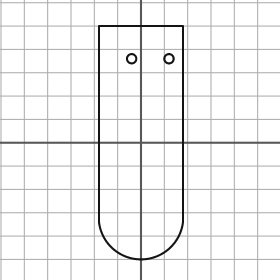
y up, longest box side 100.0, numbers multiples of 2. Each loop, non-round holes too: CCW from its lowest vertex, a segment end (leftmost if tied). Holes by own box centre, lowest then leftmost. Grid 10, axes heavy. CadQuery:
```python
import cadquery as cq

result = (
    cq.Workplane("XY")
    .moveTo(-18.0, -34.0)
    .threePointArc((0.0, -50.0), (18.0, -34.0))
    .lineTo(18.0, 50.0)
    .lineTo(-18.0, 50.0)
    .close()
    .moveTo(-4.0, 36.0)
    .circle(2.0)
    .moveTo(12.0, 36.0)
    .circle(2.0)
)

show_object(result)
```